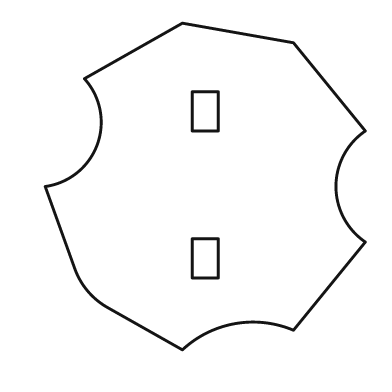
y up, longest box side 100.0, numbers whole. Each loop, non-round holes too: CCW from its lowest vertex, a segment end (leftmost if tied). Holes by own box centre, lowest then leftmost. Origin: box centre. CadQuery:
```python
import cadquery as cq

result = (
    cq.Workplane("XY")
    .moveTo(-7.0, -50.0)
    .threePointArc((9.0, -42.0), (27.0, -44.0))
    .lineTo(49.0, -17.0)
    .threePointArc((40.0, 0.0), (49.0, 17.0))
    .lineTo(27.0, 44.0)
    .lineTo(-7.0, 50.0)
    .lineTo(-37.0, 33.0)
    .threePointArc((-33.0, 13.0), (-49.0, 0.0))
    .lineTo(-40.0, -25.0)
    .threePointArc((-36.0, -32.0), (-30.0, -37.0))
    .close()
    .moveTo(-4.0, -28.0)
    .lineTo(4.0, -28.0)
    .lineTo(4.0, -16.0)
    .lineTo(-4.0, -16.0)
    .close()
    .moveTo(-4.0, 17.0)
    .lineTo(4.0, 17.0)
    .lineTo(4.0, 29.0)
    .lineTo(-4.0, 29.0)
    .close()
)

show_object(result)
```